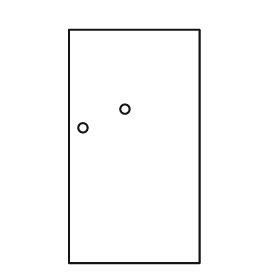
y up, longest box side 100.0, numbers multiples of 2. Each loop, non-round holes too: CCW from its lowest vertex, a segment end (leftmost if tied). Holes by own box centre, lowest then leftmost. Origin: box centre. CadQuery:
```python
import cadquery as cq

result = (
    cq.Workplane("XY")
    .moveTo(-28.0, -50.0)
    .lineTo(28.0, -50.0)
    .lineTo(28.0, 50.0)
    .lineTo(-28.0, 50.0)
    .close()
    .moveTo(-22.0, 8.0)
    .circle(2.0)
    .moveTo(-4.0, 16.0)
    .circle(2.0)
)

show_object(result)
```